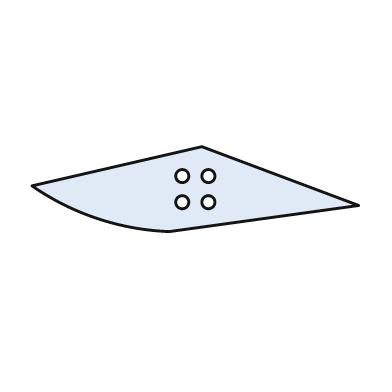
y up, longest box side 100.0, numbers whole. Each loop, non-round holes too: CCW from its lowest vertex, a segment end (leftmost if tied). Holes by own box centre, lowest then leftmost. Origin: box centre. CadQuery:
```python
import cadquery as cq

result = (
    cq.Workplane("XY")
    .moveTo(-8.0, -13.0)
    .lineTo(50.0, -5.0)
    .lineTo(2.0, 13.0)
    .lineTo(-50.0, 1.0)
    .threePointArc((-30.0, -9.0), (-8.0, -13.0))
    .close()
    .moveTo(-4.0, -4.0)
    .circle(2.0)
    .moveTo(4.0, -4.0)
    .circle(2.0)
    .moveTo(-4.0, 4.0)
    .circle(2.0)
    .moveTo(4.0, 4.0)
    .circle(2.0)
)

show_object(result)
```